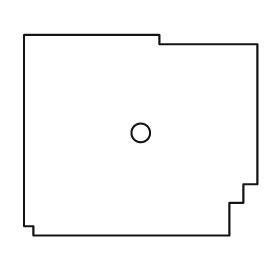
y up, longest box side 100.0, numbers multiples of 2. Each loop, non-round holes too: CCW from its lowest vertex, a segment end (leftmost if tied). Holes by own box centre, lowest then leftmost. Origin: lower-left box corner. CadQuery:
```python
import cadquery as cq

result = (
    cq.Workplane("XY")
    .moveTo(4.0, 0.0)
    .lineTo(88.0, 0.0)
    .lineTo(88.0, 14.0)
    .lineTo(94.0, 14.0)
    .lineTo(94.0, 22.0)
    .lineTo(100.0, 22.0)
    .lineTo(100.0, 82.0)
    .lineTo(58.0, 82.0)
    .lineTo(58.0, 86.0)
    .lineTo(0.0, 86.0)
    .lineTo(0.0, 4.0)
    .lineTo(4.0, 4.0)
    .close()
    .moveTo(50.0, 44.0)
    .circle(4.0)
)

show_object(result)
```